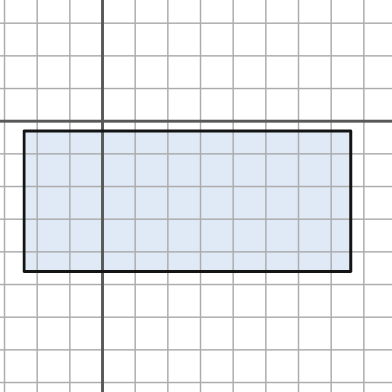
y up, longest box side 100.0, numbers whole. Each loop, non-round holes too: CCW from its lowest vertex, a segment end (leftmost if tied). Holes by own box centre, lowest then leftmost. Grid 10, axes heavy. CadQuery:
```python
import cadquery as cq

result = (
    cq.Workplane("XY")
    .moveTo(-24.0, -46.0)
    .lineTo(76.0, -46.0)
    .lineTo(76.0, -3.0)
    .lineTo(-24.0, -3.0)
    .close()
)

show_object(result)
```